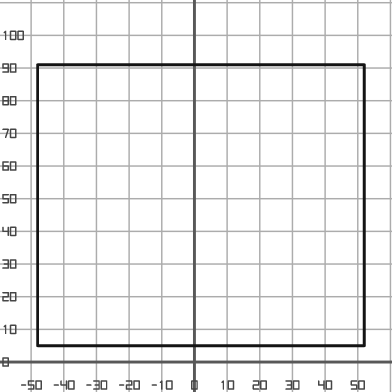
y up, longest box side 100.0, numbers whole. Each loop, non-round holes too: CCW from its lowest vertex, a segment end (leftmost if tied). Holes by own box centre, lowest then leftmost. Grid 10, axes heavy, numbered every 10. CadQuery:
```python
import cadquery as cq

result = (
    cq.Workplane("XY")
    .moveTo(-48.0, 5.0)
    .lineTo(52.0, 5.0)
    .lineTo(52.0, 91.0)
    .lineTo(-48.0, 91.0)
    .close()
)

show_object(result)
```